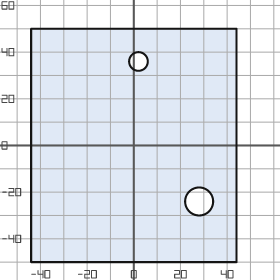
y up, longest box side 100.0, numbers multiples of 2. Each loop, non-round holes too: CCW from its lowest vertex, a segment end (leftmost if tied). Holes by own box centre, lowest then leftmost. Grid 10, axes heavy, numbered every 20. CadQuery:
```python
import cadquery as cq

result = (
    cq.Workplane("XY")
    .moveTo(-44.0, -50.0)
    .lineTo(44.0, -50.0)
    .lineTo(44.0, 50.0)
    .lineTo(-44.0, 50.0)
    .close()
    .moveTo(28.0, -24.0)
    .circle(6.0)
    .moveTo(2.0, 36.0)
    .circle(4.0)
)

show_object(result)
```